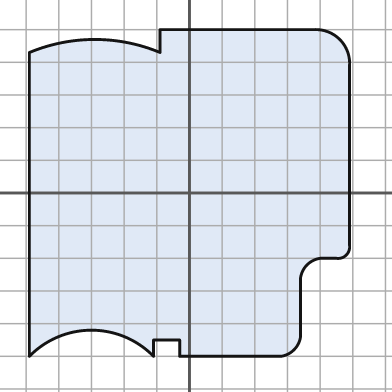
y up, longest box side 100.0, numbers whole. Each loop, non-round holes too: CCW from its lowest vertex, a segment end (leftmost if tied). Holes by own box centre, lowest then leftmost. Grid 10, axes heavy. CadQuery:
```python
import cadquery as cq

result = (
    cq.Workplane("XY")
    .moveTo(-49.0, -50.0)
    .threePointArc((-30.0, -42.0), (-11.0, -50.0))
    .lineTo(-11.0, -45.0)
    .lineTo(-3.0, -45.0)
    .lineTo(-3.0, -50.0)
    .lineTo(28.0, -50.0)
    .threePointArc((32.0, -48.0), (34.0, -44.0))
    .lineTo(34.0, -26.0)
    .threePointArc((36.0, -22.0), (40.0, -20.0))
    .lineTo(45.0, -20.0)
    .threePointArc((48.0, -19.0), (49.0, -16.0))
    .lineTo(49.0, 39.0)
    .threePointArc((46.0, 47.0), (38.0, 50.0))
    .lineTo(-9.0, 50.0)
    .lineTo(-9.0, 43.0)
    .threePointArc((-29.0, 47.0), (-49.0, 43.0))
    .close()
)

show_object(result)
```